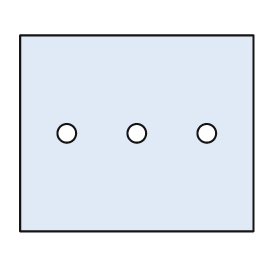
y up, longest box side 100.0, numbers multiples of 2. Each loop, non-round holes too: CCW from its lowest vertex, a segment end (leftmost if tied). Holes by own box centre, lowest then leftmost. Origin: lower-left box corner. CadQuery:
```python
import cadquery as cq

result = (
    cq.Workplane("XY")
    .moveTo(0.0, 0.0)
    .lineTo(100.0, 0.0)
    .lineTo(100.0, 84.0)
    .lineTo(0.0, 84.0)
    .close()
    .moveTo(20.0, 42.0)
    .circle(4.0)
    .moveTo(50.0, 42.0)
    .circle(4.0)
    .moveTo(80.0, 42.0)
    .circle(4.0)
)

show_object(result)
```